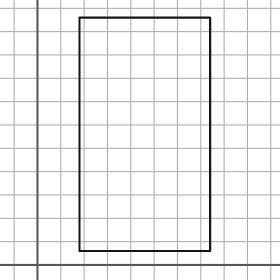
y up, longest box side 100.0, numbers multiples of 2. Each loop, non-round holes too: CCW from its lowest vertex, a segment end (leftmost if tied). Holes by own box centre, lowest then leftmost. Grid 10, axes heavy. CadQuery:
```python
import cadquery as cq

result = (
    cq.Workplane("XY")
    .moveTo(18.0, 6.0)
    .lineTo(74.0, 6.0)
    .lineTo(74.0, 106.0)
    .lineTo(18.0, 106.0)
    .close()
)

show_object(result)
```